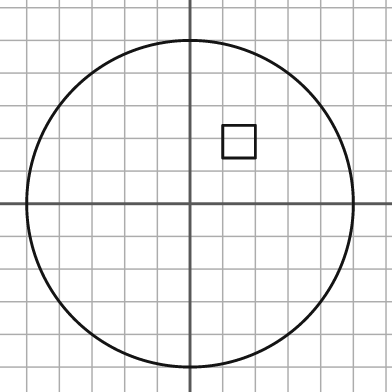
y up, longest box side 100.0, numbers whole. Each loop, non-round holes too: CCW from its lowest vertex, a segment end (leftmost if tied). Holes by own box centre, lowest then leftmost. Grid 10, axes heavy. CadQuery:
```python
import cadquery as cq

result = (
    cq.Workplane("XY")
    .moveTo(0.0, 0.0)
    .circle(50.0)
    .moveTo(10.0, 14.0)
    .lineTo(20.0, 14.0)
    .lineTo(20.0, 24.0)
    .lineTo(10.0, 24.0)
    .close()
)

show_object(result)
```